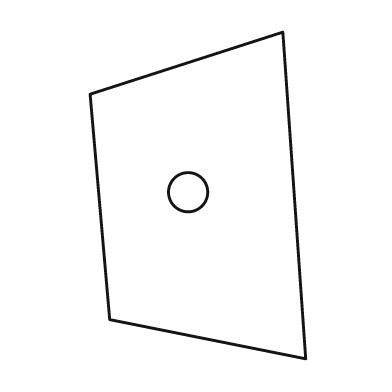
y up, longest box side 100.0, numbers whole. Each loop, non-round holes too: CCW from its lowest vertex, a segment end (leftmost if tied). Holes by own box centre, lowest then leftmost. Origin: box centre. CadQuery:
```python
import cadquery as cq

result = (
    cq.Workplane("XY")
    .moveTo(33.0, -50.0)
    .lineTo(26.0, 50.0)
    .lineTo(-33.0, 31.0)
    .lineTo(-27.0, -38.0)
    .close()
    .moveTo(-3.0, 1.0)
    .circle(6.0)
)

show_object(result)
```